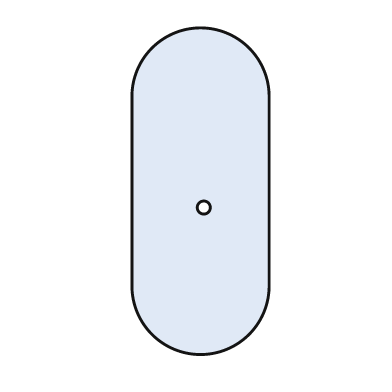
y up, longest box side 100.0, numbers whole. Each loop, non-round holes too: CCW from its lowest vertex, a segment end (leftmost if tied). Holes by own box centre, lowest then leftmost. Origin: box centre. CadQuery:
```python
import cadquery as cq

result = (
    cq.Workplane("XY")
    .moveTo(-21.0, -29.0)
    .threePointArc((0.0, -50.0), (21.0, -29.0))
    .lineTo(21.0, 29.0)
    .threePointArc((0.0, 50.0), (-21.0, 29.0))
    .close()
    .moveTo(1.0, -5.0)
    .circle(2.0)
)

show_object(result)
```